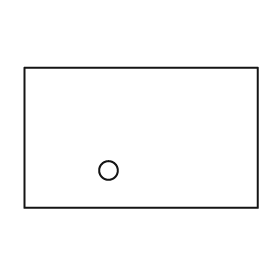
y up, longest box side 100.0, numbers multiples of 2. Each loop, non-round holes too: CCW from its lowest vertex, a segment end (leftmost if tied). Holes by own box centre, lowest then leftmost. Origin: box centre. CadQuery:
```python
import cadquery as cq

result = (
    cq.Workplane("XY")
    .moveTo(-50.0, -30.0)
    .lineTo(50.0, -30.0)
    .lineTo(50.0, 30.0)
    .lineTo(-50.0, 30.0)
    .close()
    .moveTo(-14.0, -14.0)
    .circle(4.0)
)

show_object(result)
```